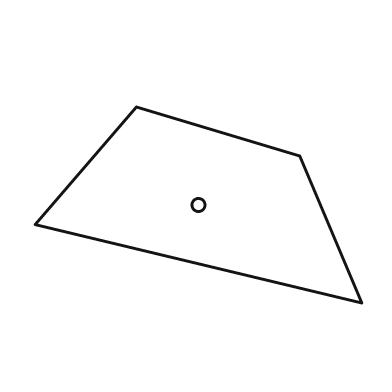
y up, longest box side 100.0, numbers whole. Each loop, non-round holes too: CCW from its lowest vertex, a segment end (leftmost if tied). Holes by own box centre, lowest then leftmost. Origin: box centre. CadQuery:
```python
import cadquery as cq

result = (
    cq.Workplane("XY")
    .moveTo(50.0, -30.0)
    .lineTo(31.0, 15.0)
    .lineTo(-19.0, 30.0)
    .lineTo(-50.0, -6.0)
    .close()
    .moveTo(0.0, 0.0)
    .circle(2.0)
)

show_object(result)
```